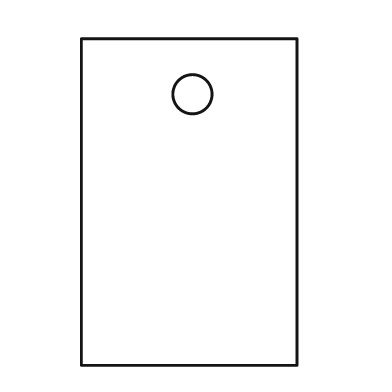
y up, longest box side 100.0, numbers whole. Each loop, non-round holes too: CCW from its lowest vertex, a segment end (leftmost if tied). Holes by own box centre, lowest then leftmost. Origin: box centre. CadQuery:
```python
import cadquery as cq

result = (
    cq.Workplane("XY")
    .moveTo(-33.0, -50.0)
    .lineTo(33.0, -50.0)
    .lineTo(33.0, 50.0)
    .lineTo(-33.0, 50.0)
    .close()
    .moveTo(1.0, 33.0)
    .circle(6.0)
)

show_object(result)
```